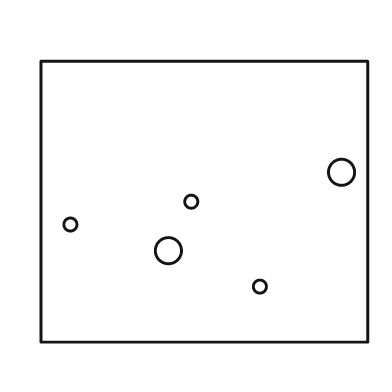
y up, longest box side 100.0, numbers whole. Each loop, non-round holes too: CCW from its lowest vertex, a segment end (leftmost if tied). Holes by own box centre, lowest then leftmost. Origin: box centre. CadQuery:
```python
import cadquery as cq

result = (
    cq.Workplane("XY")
    .moveTo(-50.0, -43.0)
    .lineTo(50.0, -43.0)
    .lineTo(50.0, 43.0)
    .lineTo(-50.0, 43.0)
    .close()
    .moveTo(17.0, -26.0)
    .circle(2.0)
    .moveTo(-11.0, -15.0)
    .circle(4.0)
    .moveTo(-41.0, -7.0)
    .circle(2.0)
    .moveTo(-4.0, 0.0)
    .circle(2.0)
    .moveTo(42.0, 9.0)
    .circle(4.0)
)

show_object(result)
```